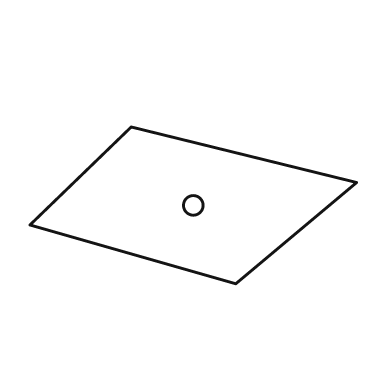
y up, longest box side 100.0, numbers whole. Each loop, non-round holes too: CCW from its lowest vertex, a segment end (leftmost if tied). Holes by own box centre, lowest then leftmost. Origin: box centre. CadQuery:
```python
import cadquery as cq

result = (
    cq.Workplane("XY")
    .moveTo(13.0, -24.0)
    .lineTo(50.0, 7.0)
    .lineTo(-19.0, 24.0)
    .lineTo(-50.0, -6.0)
    .close()
    .moveTo(0.0, 0.0)
    .circle(3.0)
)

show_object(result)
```